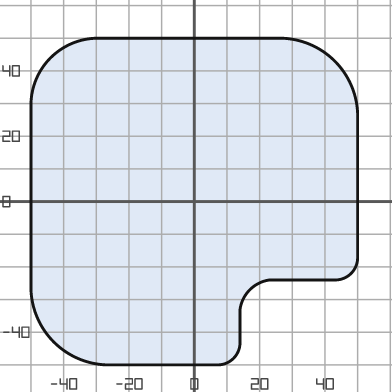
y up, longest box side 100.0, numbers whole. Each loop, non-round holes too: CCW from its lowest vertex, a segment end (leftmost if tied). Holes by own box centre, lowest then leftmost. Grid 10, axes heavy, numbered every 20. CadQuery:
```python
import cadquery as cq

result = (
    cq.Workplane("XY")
    .moveTo(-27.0, -50.0)
    .lineTo(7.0, -50.0)
    .threePointArc((12.0, -48.0), (14.0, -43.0))
    .lineTo(14.0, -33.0)
    .threePointArc((17.0, -27.0), (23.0, -24.0))
    .lineTo(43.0, -24.0)
    .threePointArc((48.0, -22.0), (50.0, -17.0))
    .lineTo(50.0, 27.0)
    .threePointArc((43.0, 43.0), (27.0, 50.0))
    .lineTo(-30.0, 50.0)
    .threePointArc((-44.0, 44.0), (-50.0, 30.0))
    .lineTo(-50.0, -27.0)
    .threePointArc((-43.0, -43.0), (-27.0, -50.0))
    .close()
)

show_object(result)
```